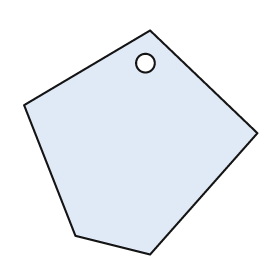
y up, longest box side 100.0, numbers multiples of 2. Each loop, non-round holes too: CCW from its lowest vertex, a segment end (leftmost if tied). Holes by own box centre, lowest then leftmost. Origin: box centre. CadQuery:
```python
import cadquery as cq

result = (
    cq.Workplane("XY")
    .moveTo(4.0, -48.0)
    .lineTo(50.0, 4.0)
    .lineTo(4.0, 48.0)
    .lineTo(-50.0, 16.0)
    .lineTo(-28.0, -40.0)
    .close()
    .moveTo(2.0, 34.0)
    .circle(4.0)
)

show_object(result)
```